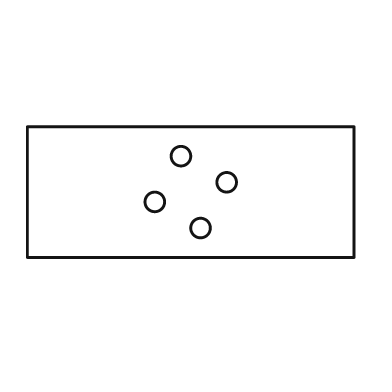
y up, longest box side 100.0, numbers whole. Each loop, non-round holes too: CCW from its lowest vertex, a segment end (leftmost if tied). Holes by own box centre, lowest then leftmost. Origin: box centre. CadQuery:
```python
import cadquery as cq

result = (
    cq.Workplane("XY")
    .moveTo(-50.0, -20.0)
    .lineTo(50.0, -20.0)
    .lineTo(50.0, 20.0)
    .lineTo(-50.0, 20.0)
    .close()
    .moveTo(3.0, -11.0)
    .circle(3.0)
    .moveTo(-11.0, -3.0)
    .circle(3.0)
    .moveTo(11.0, 3.0)
    .circle(3.0)
    .moveTo(-3.0, 11.0)
    .circle(3.0)
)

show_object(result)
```